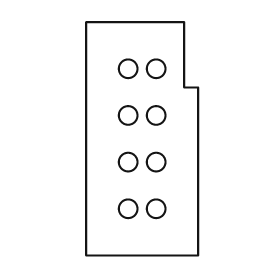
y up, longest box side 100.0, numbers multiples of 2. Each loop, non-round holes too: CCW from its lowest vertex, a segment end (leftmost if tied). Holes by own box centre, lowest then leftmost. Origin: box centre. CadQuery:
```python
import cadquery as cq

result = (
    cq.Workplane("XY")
    .moveTo(-24.0, -50.0)
    .lineTo(24.0, -50.0)
    .lineTo(24.0, 22.0)
    .lineTo(18.0, 22.0)
    .lineTo(18.0, 50.0)
    .lineTo(-24.0, 50.0)
    .close()
    .moveTo(-6.0, -30.0)
    .circle(4.0)
    .moveTo(6.0, -30.0)
    .circle(4.0)
    .moveTo(-6.0, -10.0)
    .circle(4.0)
    .moveTo(6.0, -10.0)
    .circle(4.0)
    .moveTo(-6.0, 10.0)
    .circle(4.0)
    .moveTo(6.0, 10.0)
    .circle(4.0)
    .moveTo(-6.0, 30.0)
    .circle(4.0)
    .moveTo(6.0, 30.0)
    .circle(4.0)
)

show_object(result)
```